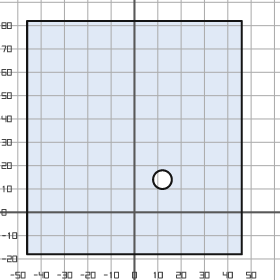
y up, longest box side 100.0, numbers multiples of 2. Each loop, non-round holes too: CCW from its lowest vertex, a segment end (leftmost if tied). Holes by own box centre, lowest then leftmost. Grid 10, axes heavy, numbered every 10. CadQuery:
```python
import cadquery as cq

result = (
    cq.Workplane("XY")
    .moveTo(-46.0, -18.0)
    .lineTo(46.0, -18.0)
    .lineTo(46.0, 82.0)
    .lineTo(-46.0, 82.0)
    .close()
    .moveTo(12.0, 14.0)
    .circle(4.0)
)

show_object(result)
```